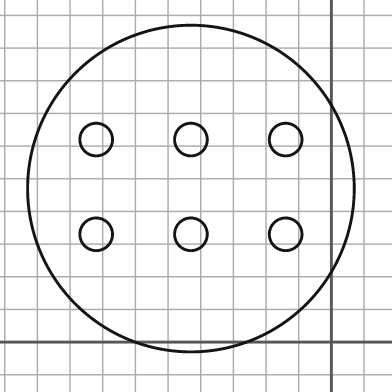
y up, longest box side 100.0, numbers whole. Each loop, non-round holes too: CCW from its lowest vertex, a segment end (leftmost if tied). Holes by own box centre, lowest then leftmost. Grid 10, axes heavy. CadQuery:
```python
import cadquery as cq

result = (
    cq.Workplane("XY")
    .moveTo(-43.0, 47.0)
    .circle(50.0)
    .moveTo(-72.0, 33.0)
    .circle(5.0)
    .moveTo(-43.0, 33.0)
    .circle(5.0)
    .moveTo(-14.0, 33.0)
    .circle(5.0)
    .moveTo(-72.0, 62.0)
    .circle(5.0)
    .moveTo(-43.0, 62.0)
    .circle(5.0)
    .moveTo(-14.0, 62.0)
    .circle(5.0)
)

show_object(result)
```